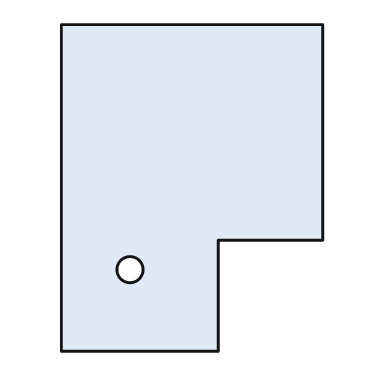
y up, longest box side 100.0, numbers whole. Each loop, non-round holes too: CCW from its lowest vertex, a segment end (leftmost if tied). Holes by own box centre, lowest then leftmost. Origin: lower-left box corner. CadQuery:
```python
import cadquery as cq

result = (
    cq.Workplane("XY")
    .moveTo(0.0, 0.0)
    .lineTo(48.0, 0.0)
    .lineTo(48.0, 34.0)
    .lineTo(80.0, 34.0)
    .lineTo(80.0, 100.0)
    .lineTo(0.0, 100.0)
    .close()
    .moveTo(21.0, 25.0)
    .circle(4.0)
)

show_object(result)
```